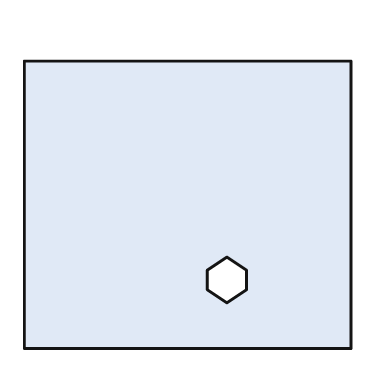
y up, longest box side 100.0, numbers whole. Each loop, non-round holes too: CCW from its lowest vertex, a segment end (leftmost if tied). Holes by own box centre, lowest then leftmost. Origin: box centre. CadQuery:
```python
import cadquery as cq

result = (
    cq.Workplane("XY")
    .moveTo(-50.0, -44.0)
    .lineTo(50.0, -44.0)
    .lineTo(50.0, 44.0)
    .lineTo(-50.0, 44.0)
    .close()
    .moveTo(12.0, -30.0)
    .lineTo(18.0, -26.0)
    .lineTo(18.0, -20.0)
    .lineTo(12.0, -16.0)
    .lineTo(6.0, -20.0)
    .lineTo(6.0, -26.0)
    .close()
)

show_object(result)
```